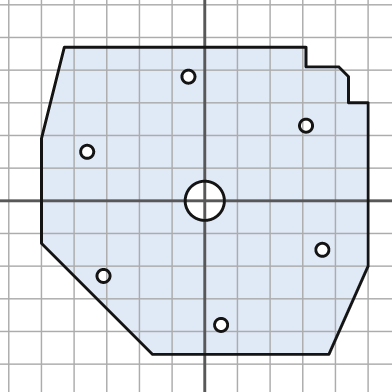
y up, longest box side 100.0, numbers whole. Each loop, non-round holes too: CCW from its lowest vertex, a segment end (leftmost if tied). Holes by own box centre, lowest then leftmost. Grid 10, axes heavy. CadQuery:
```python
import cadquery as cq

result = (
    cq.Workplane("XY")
    .moveTo(-16.0, -47.0)
    .lineTo(38.0, -47.0)
    .lineTo(50.0, -20.0)
    .lineTo(50.0, 30.0)
    .lineTo(44.0, 30.0)
    .lineTo(44.0, 38.0)
    .lineTo(41.0, 41.0)
    .lineTo(31.0, 41.0)
    .lineTo(31.0, 47.0)
    .lineTo(-43.0, 47.0)
    .lineTo(-50.0, 19.0)
    .lineTo(-50.0, -13.0)
    .close()
    .moveTo(5.0, -38.0)
    .circle(2.0)
    .moveTo(-31.0, -23.0)
    .circle(2.0)
    .moveTo(36.0, -15.0)
    .circle(2.0)
    .moveTo(0.0, 0.0)
    .circle(6.0)
    .moveTo(-36.0, 15.0)
    .circle(2.0)
    .moveTo(31.0, 23.0)
    .circle(2.0)
    .moveTo(-5.0, 38.0)
    .circle(2.0)
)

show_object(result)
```